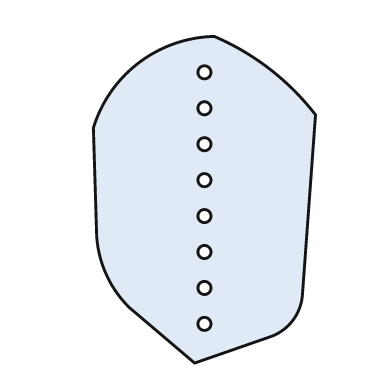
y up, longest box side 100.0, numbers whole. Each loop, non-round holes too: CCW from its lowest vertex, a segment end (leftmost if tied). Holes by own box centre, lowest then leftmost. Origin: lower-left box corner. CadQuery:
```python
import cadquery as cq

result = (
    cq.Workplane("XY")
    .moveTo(31.0, 0.0)
    .lineTo(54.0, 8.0)
    .threePointArc((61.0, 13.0), (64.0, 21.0))
    .lineTo(68.0, 76.0)
    .threePointArc((54.0, 90.0), (37.0, 100.0))
    .threePointArc((14.0, 92.0), (0.0, 72.0))
    .lineTo(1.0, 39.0)
    .threePointArc((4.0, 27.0), (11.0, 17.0))
    .close()
    .moveTo(34.0, 12.0)
    .circle(2.0)
    .moveTo(34.0, 23.0)
    .circle(2.0)
    .moveTo(34.0, 34.0)
    .circle(2.0)
    .moveTo(34.0, 45.0)
    .circle(2.0)
    .moveTo(34.0, 56.0)
    .circle(2.0)
    .moveTo(34.0, 67.0)
    .circle(2.0)
    .moveTo(34.0, 78.0)
    .circle(2.0)
    .moveTo(34.0, 89.0)
    .circle(2.0)
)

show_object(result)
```